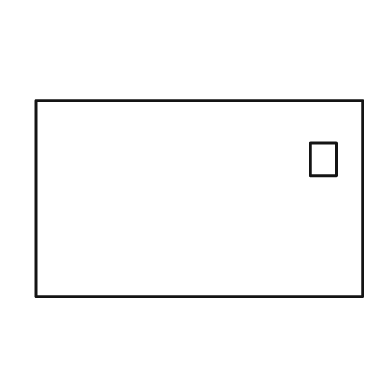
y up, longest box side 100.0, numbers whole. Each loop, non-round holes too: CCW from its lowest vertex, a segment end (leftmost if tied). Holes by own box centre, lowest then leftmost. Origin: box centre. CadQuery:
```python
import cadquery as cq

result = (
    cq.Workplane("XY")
    .moveTo(-50.0, -30.0)
    .lineTo(50.0, -30.0)
    .lineTo(50.0, 30.0)
    .lineTo(-50.0, 30.0)
    .close()
    .moveTo(34.0, 7.0)
    .lineTo(42.0, 7.0)
    .lineTo(42.0, 17.0)
    .lineTo(34.0, 17.0)
    .close()
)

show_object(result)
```